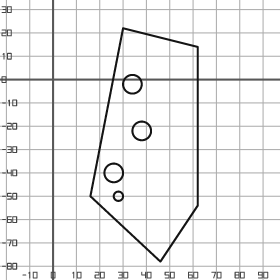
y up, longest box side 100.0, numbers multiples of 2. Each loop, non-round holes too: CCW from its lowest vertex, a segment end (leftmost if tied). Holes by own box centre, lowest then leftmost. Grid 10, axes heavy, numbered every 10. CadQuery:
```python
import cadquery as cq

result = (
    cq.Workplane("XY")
    .moveTo(46.0, -78.0)
    .lineTo(62.0, -54.0)
    .lineTo(62.0, 14.0)
    .lineTo(30.0, 22.0)
    .lineTo(16.0, -50.0)
    .close()
    .moveTo(28.0, -50.0)
    .circle(2.0)
    .moveTo(26.0, -40.0)
    .circle(4.0)
    .moveTo(38.0, -22.0)
    .circle(4.0)
    .moveTo(34.0, -2.0)
    .circle(4.0)
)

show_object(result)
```